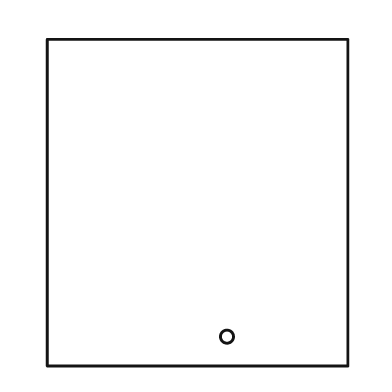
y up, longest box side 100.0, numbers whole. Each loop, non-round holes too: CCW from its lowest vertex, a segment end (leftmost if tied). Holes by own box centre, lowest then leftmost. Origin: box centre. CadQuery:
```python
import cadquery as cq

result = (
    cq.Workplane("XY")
    .moveTo(-46.0, -50.0)
    .lineTo(46.0, -50.0)
    .lineTo(46.0, 50.0)
    .lineTo(-46.0, 50.0)
    .close()
    .moveTo(9.0, -41.0)
    .circle(2.0)
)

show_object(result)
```